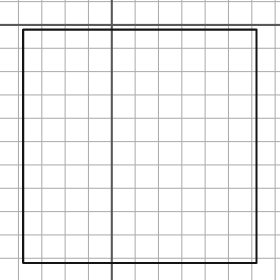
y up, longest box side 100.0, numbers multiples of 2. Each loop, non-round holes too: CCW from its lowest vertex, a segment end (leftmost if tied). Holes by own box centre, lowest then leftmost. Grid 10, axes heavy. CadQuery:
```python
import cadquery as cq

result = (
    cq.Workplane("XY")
    .moveTo(-38.0, -102.0)
    .lineTo(62.0, -102.0)
    .lineTo(62.0, -2.0)
    .lineTo(-38.0, -2.0)
    .close()
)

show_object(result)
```